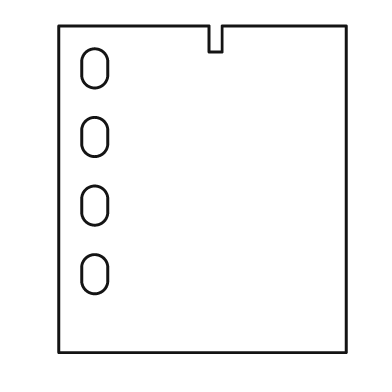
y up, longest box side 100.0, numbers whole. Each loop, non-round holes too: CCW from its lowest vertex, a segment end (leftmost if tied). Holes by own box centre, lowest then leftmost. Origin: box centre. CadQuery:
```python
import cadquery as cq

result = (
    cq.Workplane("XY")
    .moveTo(-44.0, -50.0)
    .lineTo(44.0, -50.0)
    .lineTo(44.0, 50.0)
    .lineTo(6.0, 50.0)
    .lineTo(6.0, 42.0)
    .lineTo(2.0, 42.0)
    .lineTo(2.0, 50.0)
    .lineTo(-44.0, 50.0)
    .close()
    .moveTo(-37.0, -28.0)
    .threePointArc((-33.0, -32.0), (-29.0, -28.0))
    .lineTo(-29.0, -24.0)
    .threePointArc((-33.0, -20.0), (-37.0, -24.0))
    .close()
    .moveTo(-37.0, -7.0)
    .threePointArc((-33.0, -11.0), (-29.0, -7.0))
    .lineTo(-29.0, -3.0)
    .threePointArc((-33.0, 1.0), (-37.0, -3.0))
    .close()
    .moveTo(-37.0, 14.0)
    .threePointArc((-33.0, 10.0), (-29.0, 14.0))
    .lineTo(-29.0, 18.0)
    .threePointArc((-33.0, 22.0), (-37.0, 18.0))
    .close()
    .moveTo(-37.0, 35.0)
    .threePointArc((-33.0, 31.0), (-29.0, 35.0))
    .lineTo(-29.0, 39.0)
    .threePointArc((-33.0, 43.0), (-37.0, 39.0))
    .close()
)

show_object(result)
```